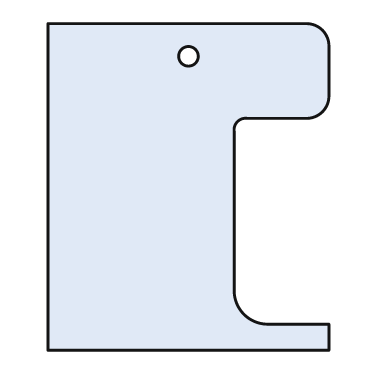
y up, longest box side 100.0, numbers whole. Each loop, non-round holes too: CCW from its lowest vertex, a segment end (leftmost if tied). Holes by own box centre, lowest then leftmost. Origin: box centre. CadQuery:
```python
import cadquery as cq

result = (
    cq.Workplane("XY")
    .moveTo(-43.0, -50.0)
    .lineTo(43.0, -50.0)
    .lineTo(43.0, -42.0)
    .lineTo(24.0, -42.0)
    .threePointArc((17.0, -39.0), (14.0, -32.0))
    .lineTo(14.0, 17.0)
    .threePointArc((15.0, 20.0), (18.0, 21.0))
    .lineTo(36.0, 21.0)
    .threePointArc((41.0, 23.0), (43.0, 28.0))
    .lineTo(43.0, 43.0)
    .threePointArc((41.0, 48.0), (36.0, 50.0))
    .lineTo(-43.0, 50.0)
    .close()
    .moveTo(0.0, 40.0)
    .circle(3.0)
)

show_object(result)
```